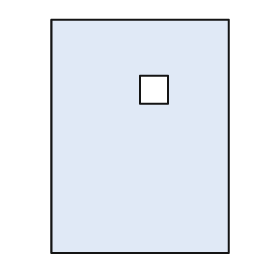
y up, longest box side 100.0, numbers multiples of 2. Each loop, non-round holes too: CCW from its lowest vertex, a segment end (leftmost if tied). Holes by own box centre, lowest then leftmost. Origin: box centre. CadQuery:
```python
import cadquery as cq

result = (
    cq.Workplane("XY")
    .moveTo(-38.0, -50.0)
    .lineTo(38.0, -50.0)
    .lineTo(38.0, 50.0)
    .lineTo(-38.0, 50.0)
    .close()
    .moveTo(0.0, 14.0)
    .lineTo(12.0, 14.0)
    .lineTo(12.0, 26.0)
    .lineTo(0.0, 26.0)
    .close()
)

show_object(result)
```